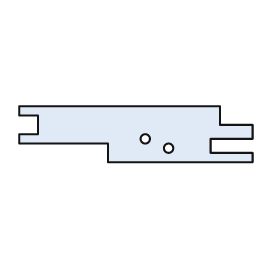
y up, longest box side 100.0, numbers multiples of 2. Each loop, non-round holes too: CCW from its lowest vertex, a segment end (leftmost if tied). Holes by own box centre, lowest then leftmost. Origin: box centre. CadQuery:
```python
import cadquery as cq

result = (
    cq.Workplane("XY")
    .moveTo(-12.0, -12.0)
    .lineTo(50.0, -12.0)
    .lineTo(50.0, -8.0)
    .lineTo(32.0, -8.0)
    .lineTo(32.0, -2.0)
    .lineTo(50.0, -2.0)
    .lineTo(50.0, 4.0)
    .lineTo(36.0, 4.0)
    .lineTo(36.0, 12.0)
    .lineTo(-50.0, 12.0)
    .lineTo(-50.0, 8.0)
    .lineTo(-42.0, 8.0)
    .lineTo(-42.0, 0.0)
    .lineTo(-50.0, 0.0)
    .lineTo(-50.0, -4.0)
    .lineTo(-12.0, -4.0)
    .close()
    .moveTo(14.0, -6.0)
    .circle(2.0)
    .moveTo(4.0, -2.0)
    .circle(2.0)
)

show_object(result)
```